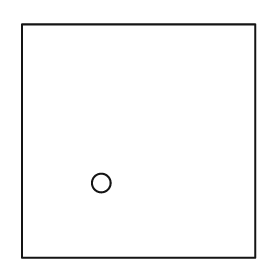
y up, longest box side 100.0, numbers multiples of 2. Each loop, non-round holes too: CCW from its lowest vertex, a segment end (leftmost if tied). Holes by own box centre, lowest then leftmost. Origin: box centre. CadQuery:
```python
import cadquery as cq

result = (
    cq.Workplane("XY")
    .moveTo(-50.0, -50.0)
    .lineTo(50.0, -50.0)
    .lineTo(50.0, 50.0)
    .lineTo(-50.0, 50.0)
    .close()
    .moveTo(-16.0, -18.0)
    .circle(4.0)
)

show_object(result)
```